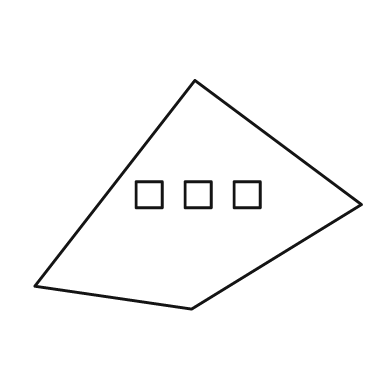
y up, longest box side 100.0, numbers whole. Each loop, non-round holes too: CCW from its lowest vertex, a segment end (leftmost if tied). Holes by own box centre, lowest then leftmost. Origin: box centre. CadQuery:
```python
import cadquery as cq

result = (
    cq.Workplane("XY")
    .moveTo(-2.0, -35.0)
    .lineTo(50.0, -3.0)
    .lineTo(-1.0, 35.0)
    .lineTo(-50.0, -28.0)
    .close()
    .moveTo(-19.0, -4.0)
    .lineTo(-11.0, -4.0)
    .lineTo(-11.0, 4.0)
    .lineTo(-19.0, 4.0)
    .close()
    .moveTo(-4.0, -4.0)
    .lineTo(4.0, -4.0)
    .lineTo(4.0, 4.0)
    .lineTo(-4.0, 4.0)
    .close()
    .moveTo(11.0, -4.0)
    .lineTo(19.0, -4.0)
    .lineTo(19.0, 4.0)
    .lineTo(11.0, 4.0)
    .close()
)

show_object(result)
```